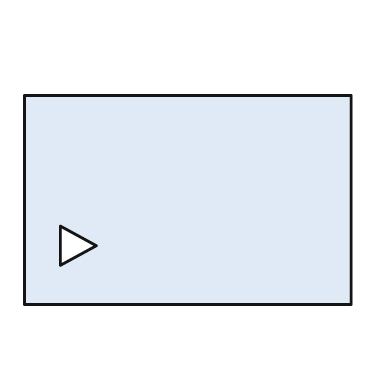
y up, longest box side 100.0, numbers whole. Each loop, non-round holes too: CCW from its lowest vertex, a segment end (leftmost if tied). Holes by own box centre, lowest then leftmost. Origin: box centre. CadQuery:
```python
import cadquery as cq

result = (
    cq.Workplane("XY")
    .moveTo(-50.0, -32.0)
    .lineTo(50.0, -32.0)
    .lineTo(50.0, 32.0)
    .lineTo(-50.0, 32.0)
    .close()
    .moveTo(-39.0, -20.0)
    .lineTo(-28.0, -14.0)
    .lineTo(-39.0, -8.0)
    .close()
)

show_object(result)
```